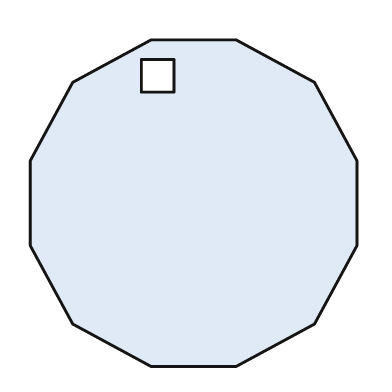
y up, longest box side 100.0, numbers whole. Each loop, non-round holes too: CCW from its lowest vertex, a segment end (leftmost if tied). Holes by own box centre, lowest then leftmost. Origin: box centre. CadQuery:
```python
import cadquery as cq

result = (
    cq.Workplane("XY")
    .moveTo(-13.0, -50.0)
    .lineTo(13.0, -50.0)
    .lineTo(37.0, -37.0)
    .lineTo(50.0, -13.0)
    .lineTo(50.0, 13.0)
    .lineTo(37.0, 37.0)
    .lineTo(13.0, 50.0)
    .lineTo(-13.0, 50.0)
    .lineTo(-37.0, 37.0)
    .lineTo(-50.0, 13.0)
    .lineTo(-50.0, -13.0)
    .lineTo(-37.0, -37.0)
    .close()
    .moveTo(-16.0, 34.0)
    .lineTo(-6.0, 34.0)
    .lineTo(-6.0, 44.0)
    .lineTo(-16.0, 44.0)
    .close()
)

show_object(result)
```